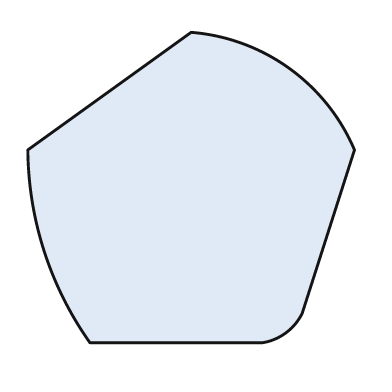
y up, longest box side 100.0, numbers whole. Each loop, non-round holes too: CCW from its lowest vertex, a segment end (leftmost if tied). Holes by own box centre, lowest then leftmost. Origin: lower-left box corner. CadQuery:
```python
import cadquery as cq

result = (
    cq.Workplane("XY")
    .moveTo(19.0, 0.0)
    .lineTo(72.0, 0.0)
    .threePointArc((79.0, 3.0), (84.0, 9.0))
    .lineTo(100.0, 59.0)
    .threePointArc((80.0, 84.0), (50.0, 95.0))
    .lineTo(0.0, 59.0)
    .threePointArc((5.0, 28.0), (19.0, 0.0))
    .close()
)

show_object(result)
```